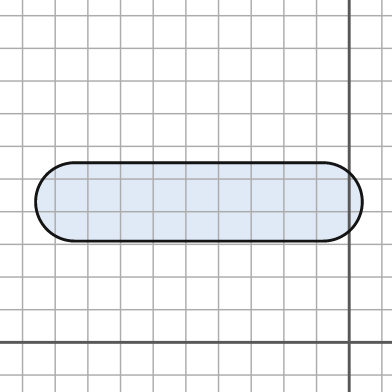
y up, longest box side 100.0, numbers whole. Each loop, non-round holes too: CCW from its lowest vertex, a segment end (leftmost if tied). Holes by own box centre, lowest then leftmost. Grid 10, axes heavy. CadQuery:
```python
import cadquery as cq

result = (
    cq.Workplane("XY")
    .moveTo(-84.0, 31.0)
    .lineTo(-8.0, 31.0)
    .threePointArc((4.0, 43.0), (-8.0, 55.0))
    .lineTo(-84.0, 55.0)
    .threePointArc((-96.0, 43.0), (-84.0, 31.0))
    .close()
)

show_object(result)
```